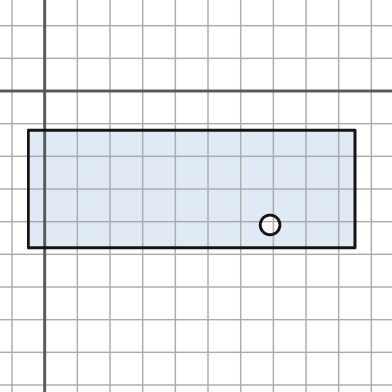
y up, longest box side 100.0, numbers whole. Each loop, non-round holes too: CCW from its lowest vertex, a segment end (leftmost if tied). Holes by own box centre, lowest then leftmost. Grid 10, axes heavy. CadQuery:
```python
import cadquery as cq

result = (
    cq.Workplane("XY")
    .moveTo(-5.0, -48.0)
    .lineTo(95.0, -48.0)
    .lineTo(95.0, -12.0)
    .lineTo(-5.0, -12.0)
    .close()
    .moveTo(69.0, -41.0)
    .circle(3.0)
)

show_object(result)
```